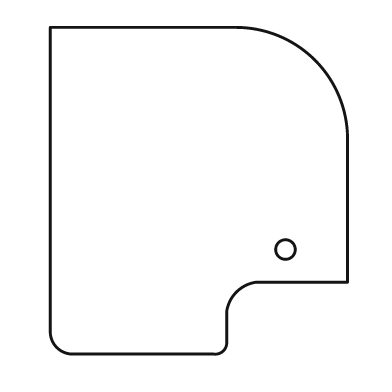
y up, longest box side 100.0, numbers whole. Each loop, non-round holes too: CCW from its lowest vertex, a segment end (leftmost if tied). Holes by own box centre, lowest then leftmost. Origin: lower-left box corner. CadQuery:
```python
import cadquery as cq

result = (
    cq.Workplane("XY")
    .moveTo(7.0, 0.0)
    .lineTo(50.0, 0.0)
    .threePointArc((53.0, 1.0), (54.0, 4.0))
    .lineTo(54.0, 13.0)
    .threePointArc((57.0, 19.0), (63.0, 22.0))
    .lineTo(91.0, 22.0)
    .lineTo(91.0, 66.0)
    .threePointArc((81.0, 90.0), (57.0, 100.0))
    .lineTo(0.0, 100.0)
    .lineTo(0.0, 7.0)
    .threePointArc((2.0, 2.0), (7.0, 0.0))
    .close()
    .moveTo(72.0, 32.0)
    .circle(3.0)
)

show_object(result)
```